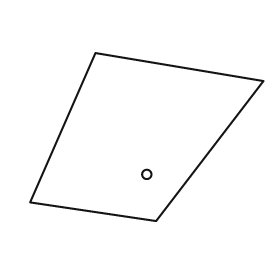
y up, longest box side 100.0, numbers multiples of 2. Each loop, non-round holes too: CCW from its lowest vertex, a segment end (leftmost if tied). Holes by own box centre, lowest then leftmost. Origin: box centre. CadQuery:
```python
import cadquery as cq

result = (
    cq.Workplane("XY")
    .moveTo(4.0, -36.0)
    .lineTo(50.0, 24.0)
    .lineTo(-22.0, 36.0)
    .lineTo(-50.0, -28.0)
    .close()
    .moveTo(0.0, -16.0)
    .circle(2.0)
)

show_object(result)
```